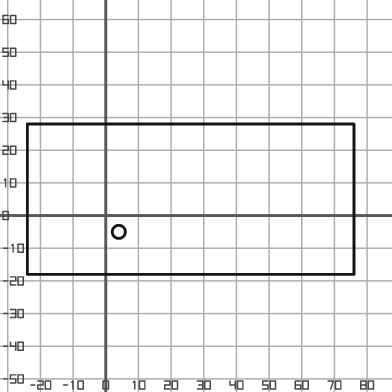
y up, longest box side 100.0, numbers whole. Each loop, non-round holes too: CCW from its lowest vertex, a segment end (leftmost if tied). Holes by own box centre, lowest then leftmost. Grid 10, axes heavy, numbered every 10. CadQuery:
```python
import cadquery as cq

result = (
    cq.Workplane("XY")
    .moveTo(-24.0, -18.0)
    .lineTo(76.0, -18.0)
    .lineTo(76.0, 28.0)
    .lineTo(-24.0, 28.0)
    .close()
    .moveTo(4.0, -5.0)
    .circle(2.0)
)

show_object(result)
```